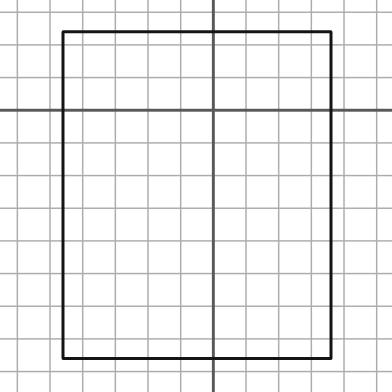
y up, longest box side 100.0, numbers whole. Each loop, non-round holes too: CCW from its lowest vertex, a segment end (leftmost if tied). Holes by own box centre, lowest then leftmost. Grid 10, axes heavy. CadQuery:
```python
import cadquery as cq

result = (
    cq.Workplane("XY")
    .moveTo(-46.0, -76.0)
    .lineTo(36.0, -76.0)
    .lineTo(36.0, 24.0)
    .lineTo(-46.0, 24.0)
    .close()
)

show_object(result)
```